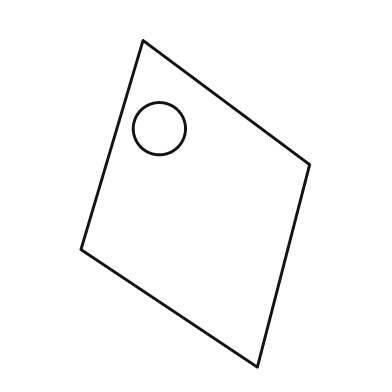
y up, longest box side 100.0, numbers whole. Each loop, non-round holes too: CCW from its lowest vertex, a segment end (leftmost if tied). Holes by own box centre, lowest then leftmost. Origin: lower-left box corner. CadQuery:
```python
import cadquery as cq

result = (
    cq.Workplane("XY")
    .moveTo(54.0, 0.0)
    .lineTo(70.0, 62.0)
    .lineTo(19.0, 100.0)
    .lineTo(0.0, 36.0)
    .close()
    .moveTo(24.0, 73.0)
    .circle(8.0)
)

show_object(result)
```